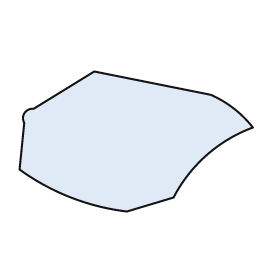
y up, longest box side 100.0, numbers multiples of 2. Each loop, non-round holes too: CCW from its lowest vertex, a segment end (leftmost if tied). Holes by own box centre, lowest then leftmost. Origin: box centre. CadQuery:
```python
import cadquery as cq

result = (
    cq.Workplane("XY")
    .moveTo(-4.0, -30.0)
    .lineTo(16.0, -24.0)
    .threePointArc((30.0, -6.0), (50.0, 6.0))
    .threePointArc((42.0, 14.0), (32.0, 20.0))
    .lineTo(-18.0, 30.0)
    .lineTo(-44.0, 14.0)
    .threePointArc((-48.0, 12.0), (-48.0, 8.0))
    .lineTo(-50.0, -12.0)
    .threePointArc((-28.0, -24.0), (-4.0, -30.0))
    .close()
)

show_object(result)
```